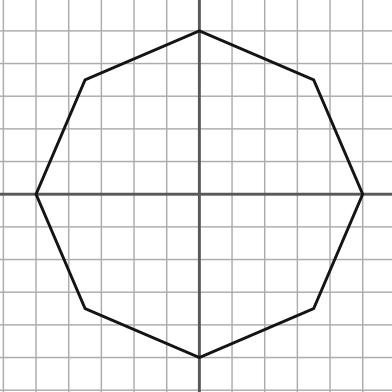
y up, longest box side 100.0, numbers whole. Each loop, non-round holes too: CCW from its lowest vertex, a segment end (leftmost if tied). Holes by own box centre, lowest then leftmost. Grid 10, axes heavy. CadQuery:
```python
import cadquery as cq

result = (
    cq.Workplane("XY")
    .moveTo(0.0, -50.0)
    .lineTo(35.0, -35.0)
    .lineTo(50.0, 0.0)
    .lineTo(35.0, 35.0)
    .lineTo(0.0, 50.0)
    .lineTo(-35.0, 35.0)
    .lineTo(-50.0, 0.0)
    .lineTo(-35.0, -35.0)
    .close()
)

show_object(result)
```